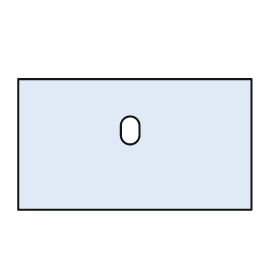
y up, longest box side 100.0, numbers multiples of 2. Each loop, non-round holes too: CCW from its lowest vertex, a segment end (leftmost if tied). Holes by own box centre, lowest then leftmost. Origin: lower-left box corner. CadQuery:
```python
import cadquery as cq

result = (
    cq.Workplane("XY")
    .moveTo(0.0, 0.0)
    .lineTo(100.0, 0.0)
    .lineTo(100.0, 56.0)
    .lineTo(0.0, 56.0)
    .close()
    .moveTo(44.0, 32.0)
    .threePointArc((48.0, 28.0), (52.0, 32.0))
    .lineTo(52.0, 36.0)
    .threePointArc((48.0, 40.0), (44.0, 36.0))
    .close()
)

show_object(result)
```